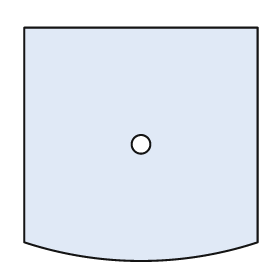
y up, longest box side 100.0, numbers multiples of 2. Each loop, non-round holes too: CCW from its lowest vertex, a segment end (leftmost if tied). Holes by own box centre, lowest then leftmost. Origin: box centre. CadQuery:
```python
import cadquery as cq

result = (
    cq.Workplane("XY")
    .moveTo(-50.0, -42.0)
    .threePointArc((0.0, -50.0), (50.0, -42.0))
    .lineTo(50.0, 50.0)
    .lineTo(-50.0, 50.0)
    .close()
    .moveTo(0.0, 0.0)
    .circle(4.0)
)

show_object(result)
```